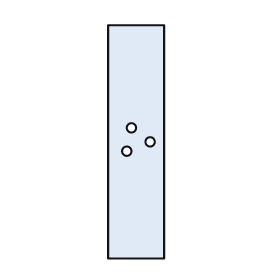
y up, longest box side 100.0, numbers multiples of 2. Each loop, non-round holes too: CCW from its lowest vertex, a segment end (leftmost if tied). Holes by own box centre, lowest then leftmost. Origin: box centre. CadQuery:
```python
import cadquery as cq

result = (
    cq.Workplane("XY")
    .moveTo(-12.0, -50.0)
    .lineTo(12.0, -50.0)
    .lineTo(12.0, 50.0)
    .lineTo(-12.0, 50.0)
    .close()
    .moveTo(-4.0, -4.0)
    .circle(2.0)
    .moveTo(6.0, 0.0)
    .circle(2.0)
    .moveTo(-2.0, 6.0)
    .circle(2.0)
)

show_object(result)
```